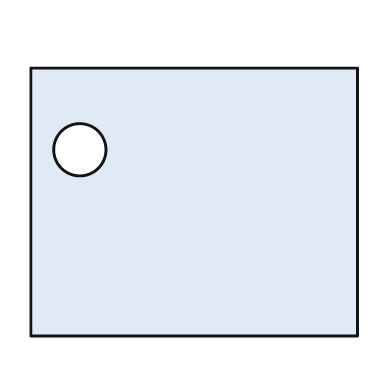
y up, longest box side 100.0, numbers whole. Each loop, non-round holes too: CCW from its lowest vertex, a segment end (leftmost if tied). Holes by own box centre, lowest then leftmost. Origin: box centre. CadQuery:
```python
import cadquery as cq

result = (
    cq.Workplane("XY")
    .moveTo(-50.0, -41.0)
    .lineTo(50.0, -41.0)
    .lineTo(50.0, 41.0)
    .lineTo(-50.0, 41.0)
    .close()
    .moveTo(-35.0, 16.0)
    .circle(8.0)
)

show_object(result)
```